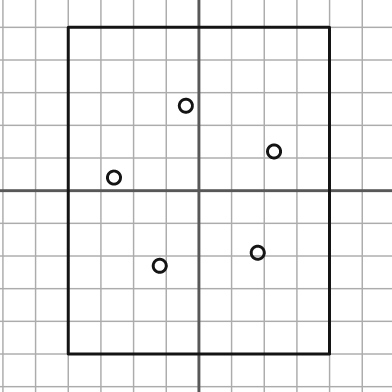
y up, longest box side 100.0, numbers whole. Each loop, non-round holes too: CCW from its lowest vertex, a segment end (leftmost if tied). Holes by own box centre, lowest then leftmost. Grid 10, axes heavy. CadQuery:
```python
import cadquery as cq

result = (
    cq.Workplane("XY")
    .moveTo(-40.0, -50.0)
    .lineTo(40.0, -50.0)
    .lineTo(40.0, 50.0)
    .lineTo(-40.0, 50.0)
    .close()
    .moveTo(-12.0, -23.0)
    .circle(2.0)
    .moveTo(18.0, -19.0)
    .circle(2.0)
    .moveTo(-26.0, 4.0)
    .circle(2.0)
    .moveTo(23.0, 12.0)
    .circle(2.0)
    .moveTo(-4.0, 26.0)
    .circle(2.0)
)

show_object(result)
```